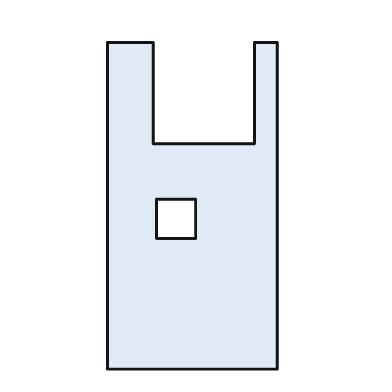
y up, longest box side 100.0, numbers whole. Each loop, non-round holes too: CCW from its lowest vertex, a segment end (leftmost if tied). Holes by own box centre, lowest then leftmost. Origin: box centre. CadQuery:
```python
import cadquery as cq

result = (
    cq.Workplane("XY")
    .moveTo(-26.0, -50.0)
    .lineTo(26.0, -50.0)
    .lineTo(26.0, 50.0)
    .lineTo(19.0, 50.0)
    .lineTo(19.0, 19.0)
    .lineTo(-12.0, 19.0)
    .lineTo(-12.0, 50.0)
    .lineTo(-26.0, 50.0)
    .close()
    .moveTo(-11.0, -10.0)
    .lineTo(1.0, -10.0)
    .lineTo(1.0, 2.0)
    .lineTo(-11.0, 2.0)
    .close()
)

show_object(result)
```